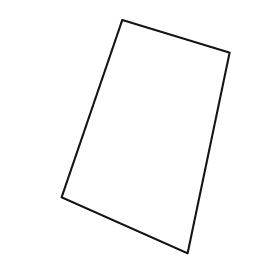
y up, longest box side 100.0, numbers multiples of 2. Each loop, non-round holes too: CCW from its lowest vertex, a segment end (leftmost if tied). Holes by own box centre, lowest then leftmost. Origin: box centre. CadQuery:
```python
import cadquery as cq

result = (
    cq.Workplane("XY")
    .moveTo(18.0, -50.0)
    .lineTo(36.0, 36.0)
    .lineTo(-10.0, 50.0)
    .lineTo(-36.0, -26.0)
    .close()
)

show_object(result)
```